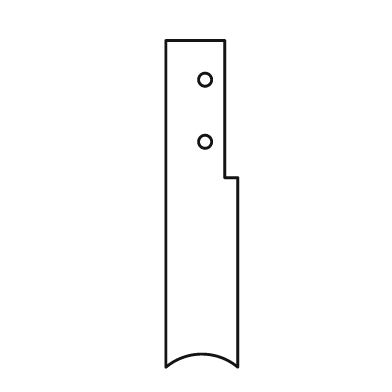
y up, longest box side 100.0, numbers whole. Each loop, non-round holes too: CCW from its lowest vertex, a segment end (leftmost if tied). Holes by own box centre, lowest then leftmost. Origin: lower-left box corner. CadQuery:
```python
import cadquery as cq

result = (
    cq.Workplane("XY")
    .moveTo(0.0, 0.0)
    .threePointArc((11.0, 4.0), (22.0, 0.0))
    .lineTo(22.0, 58.0)
    .lineTo(18.0, 58.0)
    .lineTo(18.0, 100.0)
    .lineTo(0.0, 100.0)
    .close()
    .moveTo(12.0, 69.0)
    .circle(2.0)
    .moveTo(12.0, 88.0)
    .circle(2.0)
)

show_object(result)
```